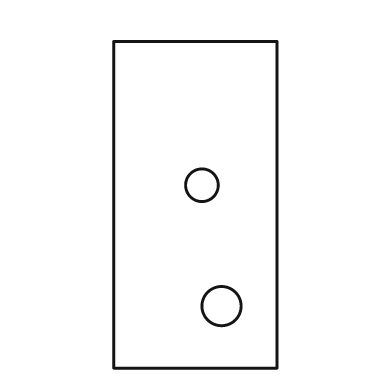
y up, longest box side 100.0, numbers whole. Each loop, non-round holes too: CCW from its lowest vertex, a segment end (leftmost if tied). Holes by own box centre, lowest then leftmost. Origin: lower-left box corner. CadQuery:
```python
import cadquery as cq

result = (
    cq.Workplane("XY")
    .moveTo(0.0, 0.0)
    .lineTo(50.0, 0.0)
    .lineTo(50.0, 100.0)
    .lineTo(0.0, 100.0)
    .close()
    .moveTo(33.0, 19.0)
    .circle(6.0)
    .moveTo(27.0, 56.0)
    .circle(5.0)
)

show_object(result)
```